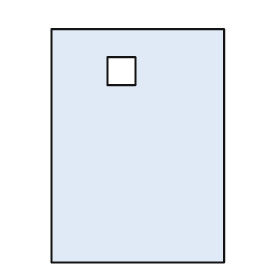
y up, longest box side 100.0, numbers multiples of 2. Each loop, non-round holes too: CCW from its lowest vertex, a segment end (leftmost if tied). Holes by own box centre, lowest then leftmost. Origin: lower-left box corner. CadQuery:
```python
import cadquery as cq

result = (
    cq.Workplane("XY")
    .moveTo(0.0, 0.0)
    .lineTo(74.0, 0.0)
    .lineTo(74.0, 100.0)
    .lineTo(0.0, 100.0)
    .close()
    .moveTo(24.0, 76.0)
    .lineTo(36.0, 76.0)
    .lineTo(36.0, 88.0)
    .lineTo(24.0, 88.0)
    .close()
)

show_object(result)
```